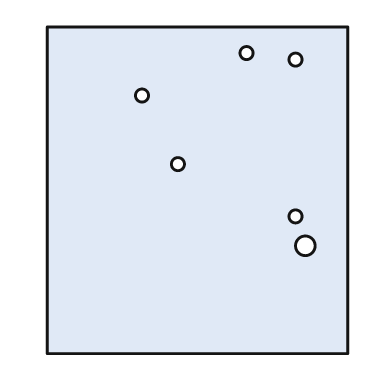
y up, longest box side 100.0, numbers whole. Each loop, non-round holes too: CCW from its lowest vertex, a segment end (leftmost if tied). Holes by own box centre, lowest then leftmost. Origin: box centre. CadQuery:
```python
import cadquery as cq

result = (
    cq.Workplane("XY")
    .moveTo(-46.0, -50.0)
    .lineTo(46.0, -50.0)
    .lineTo(46.0, 50.0)
    .lineTo(-46.0, 50.0)
    .close()
    .moveTo(33.0, -17.0)
    .circle(3.0)
    .moveTo(30.0, -8.0)
    .circle(2.0)
    .moveTo(-6.0, 8.0)
    .circle(2.0)
    .moveTo(-17.0, 29.0)
    .circle(2.0)
    .moveTo(30.0, 40.0)
    .circle(2.0)
    .moveTo(15.0, 42.0)
    .circle(2.0)
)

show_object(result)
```